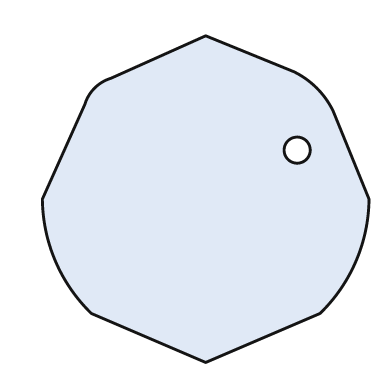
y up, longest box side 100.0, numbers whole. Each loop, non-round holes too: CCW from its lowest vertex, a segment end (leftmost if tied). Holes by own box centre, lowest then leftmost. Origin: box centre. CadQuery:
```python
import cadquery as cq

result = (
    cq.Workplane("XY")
    .moveTo(0.0, -50.0)
    .lineTo(35.0, -35.0)
    .threePointArc((46.0, -19.0), (50.0, 0.0))
    .lineTo(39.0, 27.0)
    .threePointArc((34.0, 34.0), (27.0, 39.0))
    .lineTo(0.0, 50.0)
    .lineTo(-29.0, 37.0)
    .threePointArc((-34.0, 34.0), (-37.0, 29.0))
    .lineTo(-50.0, 0.0)
    .threePointArc((-46.0, -19.0), (-35.0, -35.0))
    .close()
    .moveTo(28.0, 15.0)
    .circle(4.0)
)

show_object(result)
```